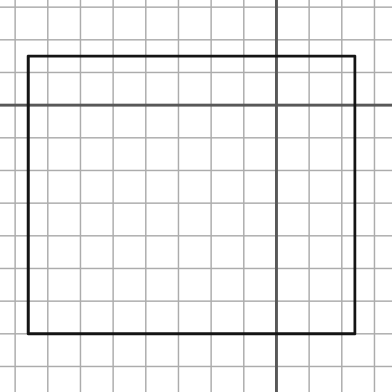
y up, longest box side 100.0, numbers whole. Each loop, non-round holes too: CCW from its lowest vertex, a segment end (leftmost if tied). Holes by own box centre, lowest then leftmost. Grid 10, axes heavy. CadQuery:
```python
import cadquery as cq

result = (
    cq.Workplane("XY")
    .moveTo(-76.0, -70.0)
    .lineTo(24.0, -70.0)
    .lineTo(24.0, 15.0)
    .lineTo(-76.0, 15.0)
    .close()
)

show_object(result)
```